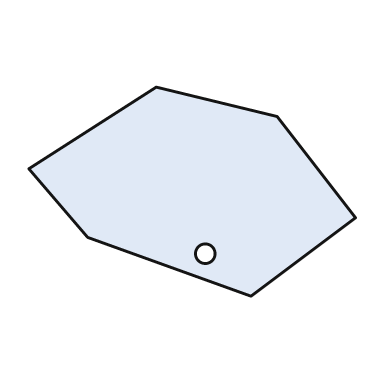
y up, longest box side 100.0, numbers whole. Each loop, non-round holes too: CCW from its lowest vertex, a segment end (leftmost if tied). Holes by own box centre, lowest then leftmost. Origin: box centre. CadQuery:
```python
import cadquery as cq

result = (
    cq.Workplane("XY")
    .moveTo(18.0, -32.0)
    .lineTo(50.0, -8.0)
    .lineTo(26.0, 23.0)
    .lineTo(-11.0, 32.0)
    .lineTo(-50.0, 7.0)
    .lineTo(-32.0, -14.0)
    .close()
    .moveTo(4.0, -19.0)
    .circle(3.0)
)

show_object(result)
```